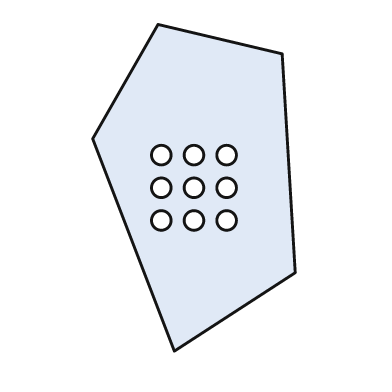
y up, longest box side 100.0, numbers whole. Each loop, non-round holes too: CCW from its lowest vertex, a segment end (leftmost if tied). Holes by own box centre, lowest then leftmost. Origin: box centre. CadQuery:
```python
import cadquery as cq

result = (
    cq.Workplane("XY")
    .moveTo(-6.0, -50.0)
    .lineTo(31.0, -26.0)
    .lineTo(27.0, 41.0)
    .lineTo(-11.0, 50.0)
    .lineTo(-31.0, 15.0)
    .close()
    .moveTo(-10.0, -10.0)
    .circle(3.0)
    .moveTo(0.0, -10.0)
    .circle(3.0)
    .moveTo(10.0, -10.0)
    .circle(3.0)
    .moveTo(-10.0, 0.0)
    .circle(3.0)
    .moveTo(0.0, 0.0)
    .circle(3.0)
    .moveTo(10.0, 0.0)
    .circle(3.0)
    .moveTo(-10.0, 10.0)
    .circle(3.0)
    .moveTo(0.0, 10.0)
    .circle(3.0)
    .moveTo(10.0, 10.0)
    .circle(3.0)
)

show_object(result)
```